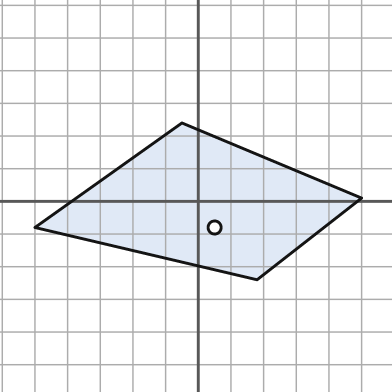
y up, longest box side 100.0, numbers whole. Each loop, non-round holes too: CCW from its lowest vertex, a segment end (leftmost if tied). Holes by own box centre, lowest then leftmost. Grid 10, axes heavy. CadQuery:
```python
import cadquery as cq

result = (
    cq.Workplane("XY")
    .moveTo(18.0, -24.0)
    .lineTo(50.0, 1.0)
    .lineTo(-5.0, 24.0)
    .lineTo(-50.0, -8.0)
    .close()
    .moveTo(5.0, -8.0)
    .circle(2.0)
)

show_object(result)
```